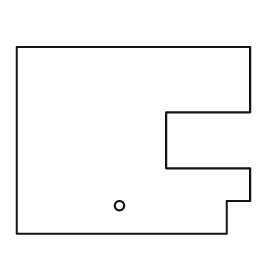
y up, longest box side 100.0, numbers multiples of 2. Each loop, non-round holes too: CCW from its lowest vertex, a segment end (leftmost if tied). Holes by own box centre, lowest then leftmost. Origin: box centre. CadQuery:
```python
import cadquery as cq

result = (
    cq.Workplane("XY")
    .moveTo(-50.0, -40.0)
    .lineTo(40.0, -40.0)
    .lineTo(40.0, -26.0)
    .lineTo(50.0, -26.0)
    .lineTo(50.0, -12.0)
    .lineTo(14.0, -12.0)
    .lineTo(14.0, 12.0)
    .lineTo(50.0, 12.0)
    .lineTo(50.0, 40.0)
    .lineTo(-50.0, 40.0)
    .close()
    .moveTo(-6.0, -28.0)
    .circle(2.0)
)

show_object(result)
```